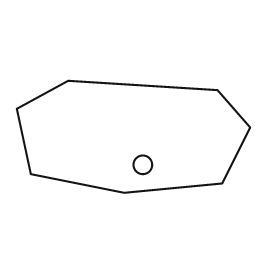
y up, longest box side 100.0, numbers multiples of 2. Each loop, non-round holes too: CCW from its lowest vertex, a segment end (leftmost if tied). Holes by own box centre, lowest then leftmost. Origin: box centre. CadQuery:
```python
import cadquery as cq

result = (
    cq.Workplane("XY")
    .moveTo(-4.0, -24.0)
    .lineTo(38.0, -20.0)
    .lineTo(50.0, 4.0)
    .lineTo(36.0, 20.0)
    .lineTo(-28.0, 24.0)
    .lineTo(-50.0, 12.0)
    .lineTo(-44.0, -16.0)
    .close()
    .moveTo(4.0, -12.0)
    .circle(4.0)
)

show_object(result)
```